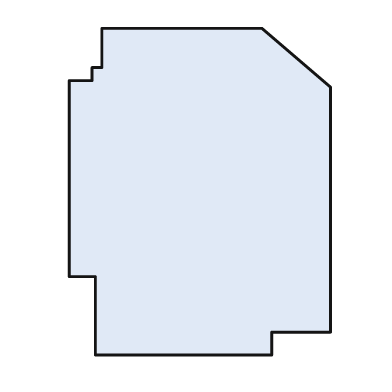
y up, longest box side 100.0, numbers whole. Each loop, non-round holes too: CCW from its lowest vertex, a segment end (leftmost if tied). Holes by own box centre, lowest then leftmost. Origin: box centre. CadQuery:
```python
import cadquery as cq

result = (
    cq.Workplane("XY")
    .moveTo(-32.0, -50.0)
    .lineTo(22.0, -50.0)
    .lineTo(22.0, -43.0)
    .lineTo(40.0, -43.0)
    .lineTo(40.0, 32.0)
    .lineTo(19.0, 50.0)
    .lineTo(-30.0, 50.0)
    .lineTo(-30.0, 38.0)
    .lineTo(-33.0, 38.0)
    .lineTo(-33.0, 34.0)
    .lineTo(-40.0, 34.0)
    .lineTo(-40.0, -26.0)
    .lineTo(-32.0, -26.0)
    .close()
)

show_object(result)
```